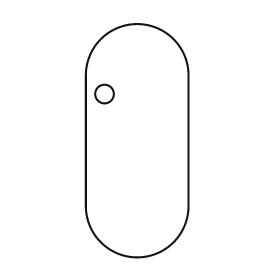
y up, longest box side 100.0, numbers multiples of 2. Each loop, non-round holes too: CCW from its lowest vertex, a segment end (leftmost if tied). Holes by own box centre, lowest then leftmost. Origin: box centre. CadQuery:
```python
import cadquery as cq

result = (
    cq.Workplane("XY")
    .moveTo(-22.0, -28.0)
    .threePointArc((0.0, -50.0), (22.0, -28.0))
    .lineTo(22.0, 28.0)
    .threePointArc((0.0, 50.0), (-22.0, 28.0))
    .close()
    .moveTo(-14.0, 20.0)
    .circle(4.0)
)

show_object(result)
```